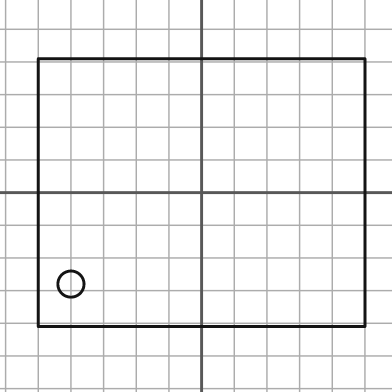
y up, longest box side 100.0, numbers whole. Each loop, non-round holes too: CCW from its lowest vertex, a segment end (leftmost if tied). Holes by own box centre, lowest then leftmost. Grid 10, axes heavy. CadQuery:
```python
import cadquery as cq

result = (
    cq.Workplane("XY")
    .moveTo(-50.0, -41.0)
    .lineTo(50.0, -41.0)
    .lineTo(50.0, 41.0)
    .lineTo(-50.0, 41.0)
    .close()
    .moveTo(-40.0, -28.0)
    .circle(4.0)
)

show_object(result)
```